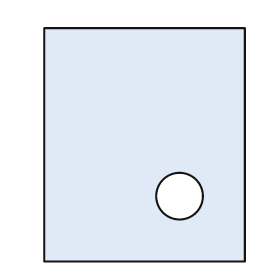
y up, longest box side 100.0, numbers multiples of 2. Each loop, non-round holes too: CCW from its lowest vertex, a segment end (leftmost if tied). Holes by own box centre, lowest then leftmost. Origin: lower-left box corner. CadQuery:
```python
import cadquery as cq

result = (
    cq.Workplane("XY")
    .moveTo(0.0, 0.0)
    .lineTo(86.0, 0.0)
    .lineTo(86.0, 100.0)
    .lineTo(0.0, 100.0)
    .close()
    .moveTo(58.0, 28.0)
    .circle(10.0)
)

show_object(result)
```